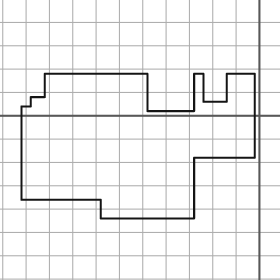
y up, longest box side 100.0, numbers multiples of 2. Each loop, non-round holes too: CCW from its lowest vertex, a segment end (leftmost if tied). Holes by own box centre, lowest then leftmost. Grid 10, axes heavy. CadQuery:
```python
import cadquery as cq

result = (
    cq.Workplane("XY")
    .moveTo(-68.0, -44.0)
    .lineTo(-28.0, -44.0)
    .lineTo(-28.0, -18.0)
    .lineTo(-2.0, -18.0)
    .lineTo(-2.0, 18.0)
    .lineTo(-14.0, 18.0)
    .lineTo(-14.0, 6.0)
    .lineTo(-24.0, 6.0)
    .lineTo(-24.0, 18.0)
    .lineTo(-28.0, 18.0)
    .lineTo(-28.0, 2.0)
    .lineTo(-48.0, 2.0)
    .lineTo(-48.0, 18.0)
    .lineTo(-92.0, 18.0)
    .lineTo(-92.0, 8.0)
    .lineTo(-98.0, 8.0)
    .lineTo(-98.0, 4.0)
    .lineTo(-102.0, 4.0)
    .lineTo(-102.0, -36.0)
    .lineTo(-68.0, -36.0)
    .close()
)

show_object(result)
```